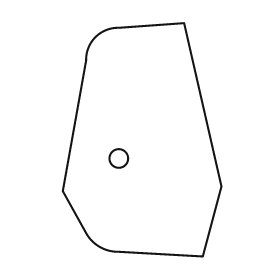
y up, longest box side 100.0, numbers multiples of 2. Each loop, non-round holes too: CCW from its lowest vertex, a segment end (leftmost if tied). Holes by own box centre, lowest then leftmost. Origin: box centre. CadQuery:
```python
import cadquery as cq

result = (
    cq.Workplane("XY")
    .moveTo(26.0, -50.0)
    .lineTo(34.0, -20.0)
    .lineTo(18.0, 50.0)
    .lineTo(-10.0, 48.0)
    .threePointArc((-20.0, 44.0), (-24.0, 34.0))
    .lineTo(-34.0, -22.0)
    .lineTo(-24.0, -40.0)
    .threePointArc((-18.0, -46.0), (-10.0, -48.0))
    .close()
    .moveTo(-10.0, -8.0)
    .circle(4.0)
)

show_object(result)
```